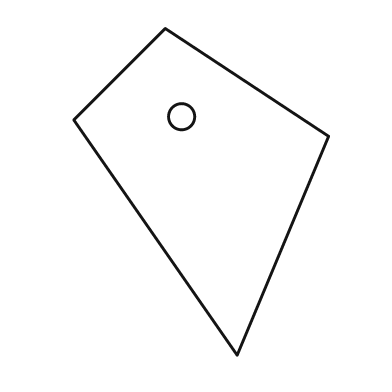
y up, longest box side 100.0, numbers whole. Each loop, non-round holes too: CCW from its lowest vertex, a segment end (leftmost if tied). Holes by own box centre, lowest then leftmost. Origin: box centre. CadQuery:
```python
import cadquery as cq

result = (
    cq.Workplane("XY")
    .moveTo(11.0, -50.0)
    .lineTo(39.0, 17.0)
    .lineTo(-11.0, 50.0)
    .lineTo(-39.0, 22.0)
    .close()
    .moveTo(-6.0, 23.0)
    .circle(4.0)
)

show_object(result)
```